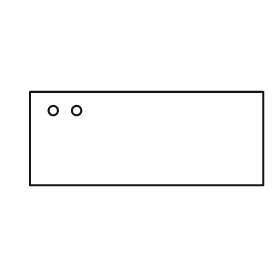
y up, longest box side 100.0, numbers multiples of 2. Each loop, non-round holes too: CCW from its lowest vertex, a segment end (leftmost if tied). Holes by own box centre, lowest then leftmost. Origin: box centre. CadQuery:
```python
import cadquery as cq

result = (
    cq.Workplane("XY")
    .moveTo(-50.0, -20.0)
    .lineTo(50.0, -20.0)
    .lineTo(50.0, 20.0)
    .lineTo(-50.0, 20.0)
    .close()
    .moveTo(-40.0, 12.0)
    .circle(2.0)
    .moveTo(-30.0, 12.0)
    .circle(2.0)
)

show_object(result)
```